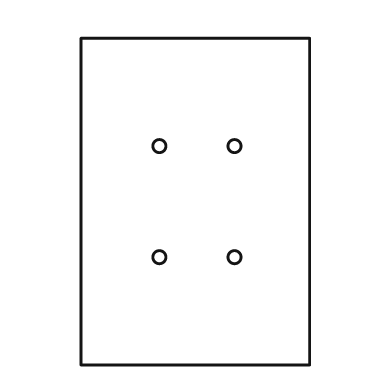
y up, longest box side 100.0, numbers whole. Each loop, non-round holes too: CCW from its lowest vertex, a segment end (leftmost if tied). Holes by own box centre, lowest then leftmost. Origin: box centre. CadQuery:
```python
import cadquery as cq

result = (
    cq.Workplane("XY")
    .moveTo(-35.0, -50.0)
    .lineTo(35.0, -50.0)
    .lineTo(35.0, 50.0)
    .lineTo(-35.0, 50.0)
    .close()
    .moveTo(-11.0, -17.0)
    .circle(2.0)
    .moveTo(12.0, -17.0)
    .circle(2.0)
    .moveTo(-11.0, 17.0)
    .circle(2.0)
    .moveTo(12.0, 17.0)
    .circle(2.0)
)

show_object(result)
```